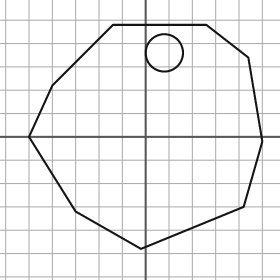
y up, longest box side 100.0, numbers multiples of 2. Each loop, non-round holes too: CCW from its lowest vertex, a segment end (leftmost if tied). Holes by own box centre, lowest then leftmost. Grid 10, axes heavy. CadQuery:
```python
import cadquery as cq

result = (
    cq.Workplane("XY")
    .moveTo(-2.0, -48.0)
    .lineTo(42.0, -30.0)
    .lineTo(50.0, -2.0)
    .lineTo(44.0, 34.0)
    .lineTo(26.0, 48.0)
    .lineTo(-14.0, 48.0)
    .lineTo(-40.0, 22.0)
    .lineTo(-50.0, 0.0)
    .lineTo(-30.0, -32.0)
    .close()
    .moveTo(8.0, 36.0)
    .circle(8.0)
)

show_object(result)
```